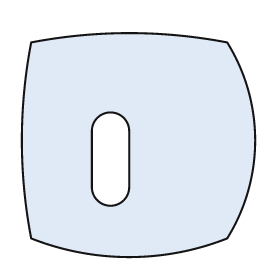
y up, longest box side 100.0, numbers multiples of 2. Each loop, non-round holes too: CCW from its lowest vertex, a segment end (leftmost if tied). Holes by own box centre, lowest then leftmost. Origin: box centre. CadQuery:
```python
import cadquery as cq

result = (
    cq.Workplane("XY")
    .moveTo(-46.0, -40.0)
    .threePointArc((-4.0, -48.0), (38.0, -40.0))
    .threePointArc((50.0, 2.0), (38.0, 44.0))
    .threePointArc((-4.0, 48.0), (-46.0, 44.0))
    .threePointArc((-50.0, 2.0), (-46.0, -40.0))
    .close()
    .moveTo(-20.0, -18.0)
    .threePointArc((-12.0, -26.0), (-4.0, -18.0))
    .lineTo(-4.0, 6.0)
    .threePointArc((-12.0, 14.0), (-20.0, 6.0))
    .close()
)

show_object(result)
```